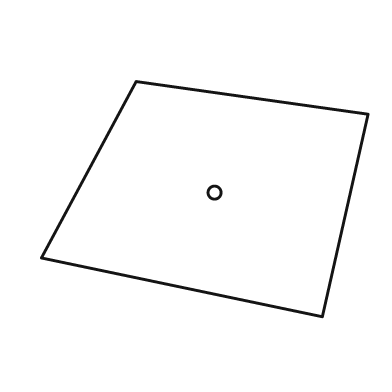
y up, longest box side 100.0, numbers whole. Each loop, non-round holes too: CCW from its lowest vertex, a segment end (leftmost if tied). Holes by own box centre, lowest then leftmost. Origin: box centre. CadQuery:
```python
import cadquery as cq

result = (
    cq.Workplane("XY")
    .moveTo(36.0, -36.0)
    .lineTo(50.0, 26.0)
    .lineTo(-21.0, 36.0)
    .lineTo(-50.0, -18.0)
    .close()
    .moveTo(3.0, 2.0)
    .circle(2.0)
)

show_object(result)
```